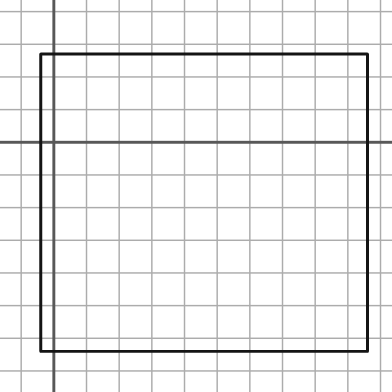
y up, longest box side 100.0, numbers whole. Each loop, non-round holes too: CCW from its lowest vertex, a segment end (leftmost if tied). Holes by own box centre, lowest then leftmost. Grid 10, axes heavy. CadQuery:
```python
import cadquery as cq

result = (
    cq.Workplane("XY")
    .moveTo(-4.0, -64.0)
    .lineTo(96.0, -64.0)
    .lineTo(96.0, 27.0)
    .lineTo(-4.0, 27.0)
    .close()
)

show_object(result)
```